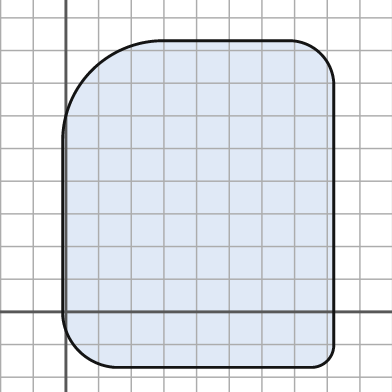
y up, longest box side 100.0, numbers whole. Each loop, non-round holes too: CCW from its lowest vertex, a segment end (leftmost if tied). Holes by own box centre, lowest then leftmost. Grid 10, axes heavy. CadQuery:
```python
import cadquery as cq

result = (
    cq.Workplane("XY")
    .moveTo(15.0, -17.0)
    .lineTo(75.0, -17.0)
    .threePointArc((80.0, -15.0), (82.0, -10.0))
    .lineTo(82.0, 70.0)
    .threePointArc((78.0, 79.0), (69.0, 83.0))
    .lineTo(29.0, 83.0)
    .threePointArc((8.0, 74.0), (-1.0, 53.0))
    .lineTo(-1.0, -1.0)
    .threePointArc((4.0, -12.0), (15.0, -17.0))
    .close()
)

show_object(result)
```